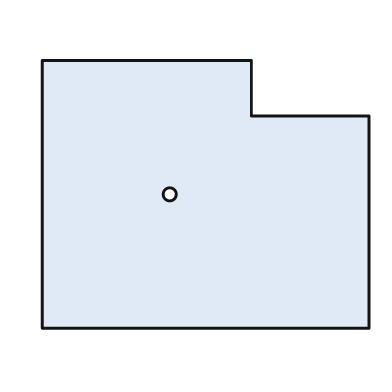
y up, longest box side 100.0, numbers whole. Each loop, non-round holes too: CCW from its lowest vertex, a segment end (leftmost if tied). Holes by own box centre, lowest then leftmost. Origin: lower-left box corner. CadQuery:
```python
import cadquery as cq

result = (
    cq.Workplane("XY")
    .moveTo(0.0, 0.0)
    .lineTo(100.0, 0.0)
    .lineTo(100.0, 65.0)
    .lineTo(64.0, 65.0)
    .lineTo(64.0, 82.0)
    .lineTo(0.0, 82.0)
    .close()
    .moveTo(39.0, 41.0)
    .circle(2.0)
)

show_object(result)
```